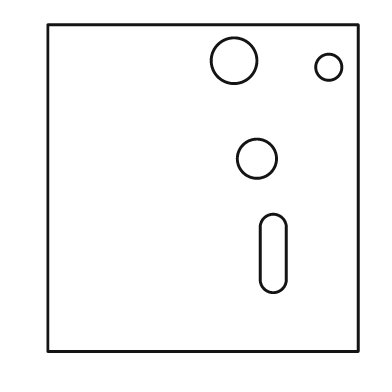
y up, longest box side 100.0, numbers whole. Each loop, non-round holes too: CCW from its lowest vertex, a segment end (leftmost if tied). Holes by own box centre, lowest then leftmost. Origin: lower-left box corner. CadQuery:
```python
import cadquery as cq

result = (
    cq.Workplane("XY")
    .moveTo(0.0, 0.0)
    .lineTo(95.0, 0.0)
    .lineTo(95.0, 100.0)
    .lineTo(0.0, 100.0)
    .close()
    .moveTo(65.0, 22.0)
    .threePointArc((69.0, 18.0), (73.0, 22.0))
    .lineTo(73.0, 38.0)
    .threePointArc((69.0, 42.0), (65.0, 38.0))
    .close()
    .moveTo(64.0, 59.0)
    .circle(6.0)
    .moveTo(86.0, 87.0)
    .circle(4.0)
    .moveTo(57.0, 89.0)
    .circle(7.0)
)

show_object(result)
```